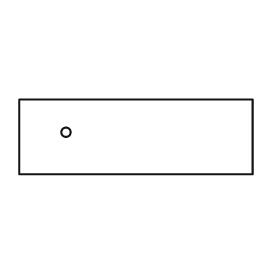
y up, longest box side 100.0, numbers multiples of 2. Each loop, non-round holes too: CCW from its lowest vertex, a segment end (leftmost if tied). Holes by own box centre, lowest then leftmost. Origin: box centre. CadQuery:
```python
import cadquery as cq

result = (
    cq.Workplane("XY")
    .moveTo(-50.0, -16.0)
    .lineTo(50.0, -16.0)
    .lineTo(50.0, 16.0)
    .lineTo(-50.0, 16.0)
    .close()
    .moveTo(-30.0, 2.0)
    .circle(2.0)
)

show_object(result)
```